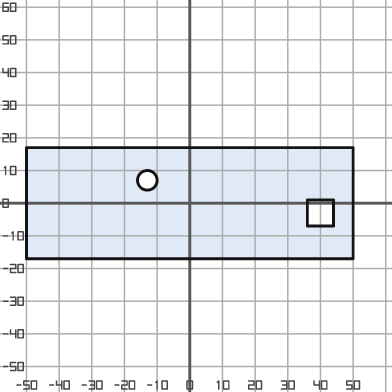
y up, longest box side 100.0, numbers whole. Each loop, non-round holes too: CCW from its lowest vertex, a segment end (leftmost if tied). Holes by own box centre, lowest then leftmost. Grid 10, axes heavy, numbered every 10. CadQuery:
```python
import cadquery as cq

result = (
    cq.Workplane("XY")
    .moveTo(-50.0, -17.0)
    .lineTo(50.0, -17.0)
    .lineTo(50.0, 17.0)
    .lineTo(-50.0, 17.0)
    .close()
    .moveTo(36.0, -7.0)
    .lineTo(44.0, -7.0)
    .lineTo(44.0, 1.0)
    .lineTo(36.0, 1.0)
    .close()
    .moveTo(-13.0, 7.0)
    .circle(3.0)
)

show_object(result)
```